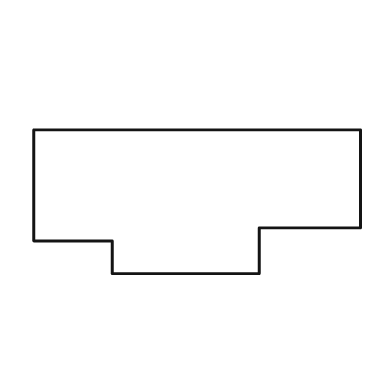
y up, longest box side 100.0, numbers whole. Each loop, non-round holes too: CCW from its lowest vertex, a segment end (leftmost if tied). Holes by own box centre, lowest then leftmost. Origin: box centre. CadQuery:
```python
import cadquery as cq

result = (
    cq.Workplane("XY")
    .moveTo(-26.0, -22.0)
    .lineTo(19.0, -22.0)
    .lineTo(19.0, -8.0)
    .lineTo(50.0, -8.0)
    .lineTo(50.0, 22.0)
    .lineTo(-50.0, 22.0)
    .lineTo(-50.0, -12.0)
    .lineTo(-26.0, -12.0)
    .close()
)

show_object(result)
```